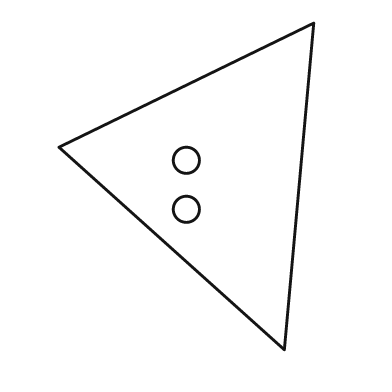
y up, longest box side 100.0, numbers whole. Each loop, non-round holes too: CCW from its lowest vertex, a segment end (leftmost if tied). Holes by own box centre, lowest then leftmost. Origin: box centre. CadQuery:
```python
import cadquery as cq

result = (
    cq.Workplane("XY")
    .moveTo(30.0, -50.0)
    .lineTo(39.0, 50.0)
    .lineTo(-39.0, 12.0)
    .close()
    .moveTo(0.0, -7.0)
    .circle(4.0)
    .moveTo(0.0, 8.0)
    .circle(4.0)
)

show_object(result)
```